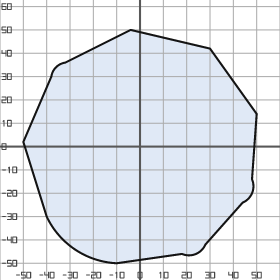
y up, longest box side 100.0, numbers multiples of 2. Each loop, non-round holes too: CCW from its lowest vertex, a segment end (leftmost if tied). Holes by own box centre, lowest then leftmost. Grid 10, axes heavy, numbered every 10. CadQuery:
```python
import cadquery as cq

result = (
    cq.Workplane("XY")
    .moveTo(-10.0, -50.0)
    .lineTo(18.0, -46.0)
    .threePointArc((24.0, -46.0), (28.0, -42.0))
    .lineTo(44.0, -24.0)
    .threePointArc((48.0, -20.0), (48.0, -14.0))
    .lineTo(50.0, 14.0)
    .lineTo(30.0, 42.0)
    .lineTo(-4.0, 50.0)
    .lineTo(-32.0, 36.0)
    .threePointArc((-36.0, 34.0), (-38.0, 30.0))
    .lineTo(-50.0, 2.0)
    .lineTo(-40.0, -30.0)
    .threePointArc((-28.0, -44.0), (-10.0, -50.0))
    .close()
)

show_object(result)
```